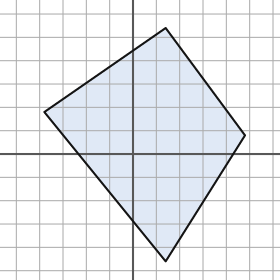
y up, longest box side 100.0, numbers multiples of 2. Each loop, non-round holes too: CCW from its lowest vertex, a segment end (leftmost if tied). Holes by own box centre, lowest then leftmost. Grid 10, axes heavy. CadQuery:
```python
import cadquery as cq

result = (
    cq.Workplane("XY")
    .moveTo(14.0, -46.0)
    .lineTo(48.0, 8.0)
    .lineTo(14.0, 54.0)
    .lineTo(-38.0, 18.0)
    .close()
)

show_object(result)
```